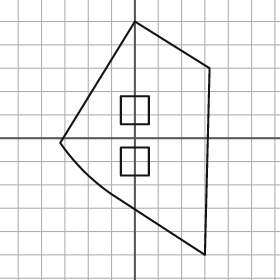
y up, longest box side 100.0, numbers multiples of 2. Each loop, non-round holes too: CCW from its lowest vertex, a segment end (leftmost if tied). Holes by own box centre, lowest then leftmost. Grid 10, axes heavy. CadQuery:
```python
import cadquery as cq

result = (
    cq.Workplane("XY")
    .moveTo(30.0, -50.0)
    .lineTo(32.0, 30.0)
    .lineTo(0.0, 50.0)
    .lineTo(-32.0, -2.0)
    .threePointArc((-22.0, -14.0), (-10.0, -24.0))
    .close()
    .moveTo(-6.0, -16.0)
    .lineTo(6.0, -16.0)
    .lineTo(6.0, -4.0)
    .lineTo(-6.0, -4.0)
    .close()
    .moveTo(-6.0, 6.0)
    .lineTo(6.0, 6.0)
    .lineTo(6.0, 18.0)
    .lineTo(-6.0, 18.0)
    .close()
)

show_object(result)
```